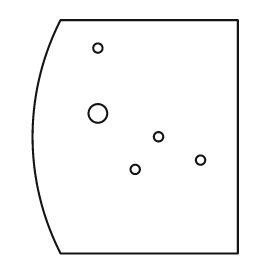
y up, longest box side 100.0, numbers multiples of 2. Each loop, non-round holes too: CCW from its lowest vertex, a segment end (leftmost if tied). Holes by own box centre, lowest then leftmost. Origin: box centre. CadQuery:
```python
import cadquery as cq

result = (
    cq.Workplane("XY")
    .moveTo(-32.0, -50.0)
    .lineTo(44.0, -50.0)
    .lineTo(44.0, 50.0)
    .lineTo(-32.0, 50.0)
    .threePointArc((-44.0, 0.0), (-32.0, -50.0))
    .close()
    .moveTo(0.0, -14.0)
    .circle(2.0)
    .moveTo(28.0, -10.0)
    .circle(2.0)
    .moveTo(10.0, 0.0)
    .circle(2.0)
    .moveTo(-16.0, 10.0)
    .circle(4.0)
    .moveTo(-16.0, 38.0)
    .circle(2.0)
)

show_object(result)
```